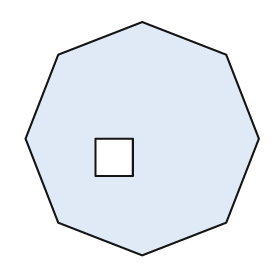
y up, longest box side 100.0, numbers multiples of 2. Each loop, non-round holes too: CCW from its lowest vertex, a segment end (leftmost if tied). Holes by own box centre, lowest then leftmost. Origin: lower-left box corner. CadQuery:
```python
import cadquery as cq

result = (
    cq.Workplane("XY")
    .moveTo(50.0, 0.0)
    .lineTo(86.0, 14.0)
    .lineTo(100.0, 50.0)
    .lineTo(86.0, 86.0)
    .lineTo(50.0, 100.0)
    .lineTo(14.0, 86.0)
    .lineTo(0.0, 50.0)
    .lineTo(14.0, 14.0)
    .close()
    .moveTo(30.0, 34.0)
    .lineTo(46.0, 34.0)
    .lineTo(46.0, 50.0)
    .lineTo(30.0, 50.0)
    .close()
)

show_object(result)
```